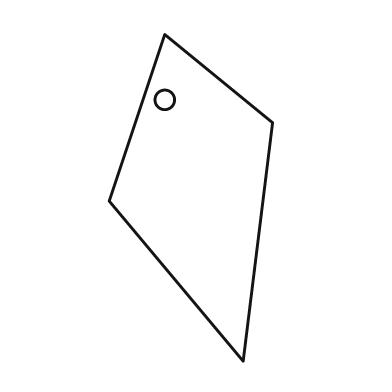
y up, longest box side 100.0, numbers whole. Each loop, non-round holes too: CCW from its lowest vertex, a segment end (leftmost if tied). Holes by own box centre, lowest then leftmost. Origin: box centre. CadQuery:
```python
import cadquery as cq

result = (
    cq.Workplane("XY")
    .moveTo(16.0, -50.0)
    .lineTo(25.0, 23.0)
    .lineTo(-8.0, 50.0)
    .lineTo(-25.0, -1.0)
    .close()
    .moveTo(-8.0, 30.0)
    .circle(3.0)
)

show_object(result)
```